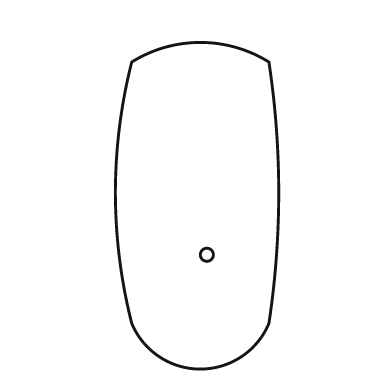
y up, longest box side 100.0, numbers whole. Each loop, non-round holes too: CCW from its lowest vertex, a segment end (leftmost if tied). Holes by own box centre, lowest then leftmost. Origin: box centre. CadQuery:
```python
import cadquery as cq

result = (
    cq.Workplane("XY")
    .moveTo(-20.0, -36.0)
    .threePointArc((1.0, -50.0), (22.0, -36.0))
    .threePointArc((25.0, 4.0), (22.0, 44.0))
    .threePointArc((1.0, 50.0), (-20.0, 44.0))
    .threePointArc((-25.0, 4.0), (-20.0, -36.0))
    .close()
    .moveTo(3.0, -15.0)
    .circle(2.0)
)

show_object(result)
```